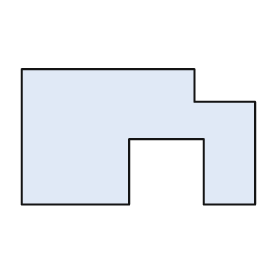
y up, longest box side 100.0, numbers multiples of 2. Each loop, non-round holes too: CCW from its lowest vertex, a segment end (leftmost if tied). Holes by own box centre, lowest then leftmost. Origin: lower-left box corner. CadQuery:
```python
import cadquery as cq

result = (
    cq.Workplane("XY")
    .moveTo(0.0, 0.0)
    .lineTo(46.0, 0.0)
    .lineTo(46.0, 28.0)
    .lineTo(78.0, 28.0)
    .lineTo(78.0, 0.0)
    .lineTo(100.0, 0.0)
    .lineTo(100.0, 44.0)
    .lineTo(74.0, 44.0)
    .lineTo(74.0, 58.0)
    .lineTo(0.0, 58.0)
    .close()
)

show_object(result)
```